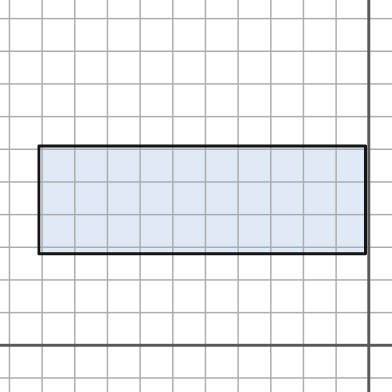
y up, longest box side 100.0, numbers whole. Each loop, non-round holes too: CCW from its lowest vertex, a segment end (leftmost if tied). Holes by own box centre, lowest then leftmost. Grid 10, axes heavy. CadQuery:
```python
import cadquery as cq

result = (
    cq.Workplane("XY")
    .moveTo(-101.0, 28.0)
    .lineTo(-1.0, 28.0)
    .lineTo(-1.0, 61.0)
    .lineTo(-101.0, 61.0)
    .close()
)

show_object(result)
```